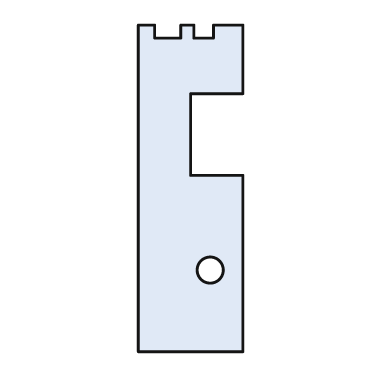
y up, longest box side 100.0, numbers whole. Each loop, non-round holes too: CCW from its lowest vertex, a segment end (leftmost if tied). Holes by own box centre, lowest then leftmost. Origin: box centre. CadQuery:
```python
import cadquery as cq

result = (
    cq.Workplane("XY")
    .moveTo(-16.0, -50.0)
    .lineTo(16.0, -50.0)
    .lineTo(16.0, 4.0)
    .lineTo(0.0, 4.0)
    .lineTo(0.0, 29.0)
    .lineTo(16.0, 29.0)
    .lineTo(16.0, 50.0)
    .lineTo(7.0, 50.0)
    .lineTo(7.0, 46.0)
    .lineTo(1.0, 46.0)
    .lineTo(1.0, 50.0)
    .lineTo(-3.0, 50.0)
    .lineTo(-3.0, 46.0)
    .lineTo(-11.0, 46.0)
    .lineTo(-11.0, 50.0)
    .lineTo(-16.0, 50.0)
    .close()
    .moveTo(6.0, -25.0)
    .circle(4.0)
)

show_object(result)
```